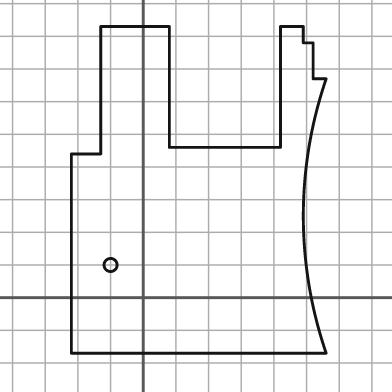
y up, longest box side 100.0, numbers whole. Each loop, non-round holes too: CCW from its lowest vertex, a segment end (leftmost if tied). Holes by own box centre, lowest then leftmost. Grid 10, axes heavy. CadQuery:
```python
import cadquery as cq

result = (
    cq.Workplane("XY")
    .moveTo(-22.0, -17.0)
    .lineTo(56.0, -17.0)
    .threePointArc((49.0, 25.0), (56.0, 67.0))
    .lineTo(52.0, 67.0)
    .lineTo(52.0, 78.0)
    .lineTo(49.0, 78.0)
    .lineTo(49.0, 83.0)
    .lineTo(42.0, 83.0)
    .lineTo(42.0, 46.0)
    .lineTo(8.0, 46.0)
    .lineTo(8.0, 83.0)
    .lineTo(-13.0, 83.0)
    .lineTo(-13.0, 44.0)
    .lineTo(-22.0, 44.0)
    .close()
    .moveTo(-10.0, 10.0)
    .circle(2.0)
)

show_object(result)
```